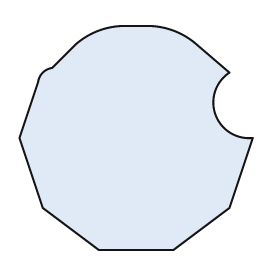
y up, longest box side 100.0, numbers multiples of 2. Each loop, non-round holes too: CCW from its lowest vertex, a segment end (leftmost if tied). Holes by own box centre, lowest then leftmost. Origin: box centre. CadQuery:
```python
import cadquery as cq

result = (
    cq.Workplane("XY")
    .moveTo(-16.0, -48.0)
    .lineTo(16.0, -48.0)
    .lineTo(40.0, -30.0)
    .lineTo(50.0, 0.0)
    .threePointArc((34.0, 10.0), (40.0, 28.0))
    .lineTo(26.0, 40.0)
    .threePointArc((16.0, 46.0), (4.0, 48.0))
    .lineTo(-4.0, 48.0)
    .threePointArc((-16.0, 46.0), (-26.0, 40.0))
    .lineTo(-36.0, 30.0)
    .threePointArc((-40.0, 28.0), (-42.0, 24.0))
    .lineTo(-50.0, 0.0)
    .lineTo(-40.0, -30.0)
    .close()
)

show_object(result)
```